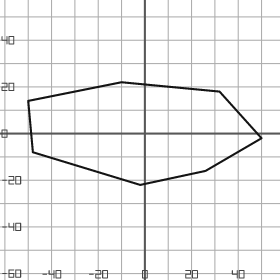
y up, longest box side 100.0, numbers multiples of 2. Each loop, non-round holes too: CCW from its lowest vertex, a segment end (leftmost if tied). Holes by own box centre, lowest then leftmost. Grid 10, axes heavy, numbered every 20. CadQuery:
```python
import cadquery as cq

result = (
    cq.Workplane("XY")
    .moveTo(-2.0, -22.0)
    .lineTo(26.0, -16.0)
    .lineTo(50.0, -2.0)
    .lineTo(32.0, 18.0)
    .lineTo(-10.0, 22.0)
    .lineTo(-50.0, 14.0)
    .lineTo(-48.0, -8.0)
    .close()
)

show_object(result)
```